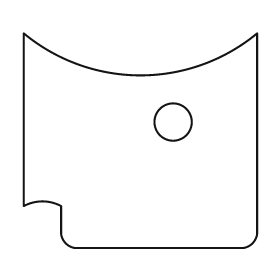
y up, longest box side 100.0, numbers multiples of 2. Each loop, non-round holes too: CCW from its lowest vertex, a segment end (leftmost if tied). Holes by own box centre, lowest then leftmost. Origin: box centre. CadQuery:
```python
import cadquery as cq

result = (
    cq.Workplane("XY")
    .moveTo(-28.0, -46.0)
    .lineTo(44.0, -46.0)
    .threePointArc((48.0, -44.0), (50.0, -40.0))
    .lineTo(50.0, 46.0)
    .threePointArc((0.0, 28.0), (-50.0, 46.0))
    .lineTo(-50.0, -28.0)
    .threePointArc((-42.0, -26.0), (-34.0, -28.0))
    .lineTo(-34.0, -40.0)
    .threePointArc((-32.0, -44.0), (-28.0, -46.0))
    .close()
    .moveTo(14.0, 8.0)
    .circle(8.0)
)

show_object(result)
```